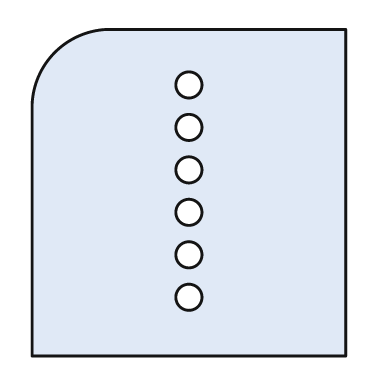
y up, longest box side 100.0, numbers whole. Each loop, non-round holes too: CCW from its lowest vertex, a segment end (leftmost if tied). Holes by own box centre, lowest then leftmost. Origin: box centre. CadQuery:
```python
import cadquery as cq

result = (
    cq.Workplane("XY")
    .moveTo(-48.0, -50.0)
    .lineTo(48.0, -50.0)
    .lineTo(48.0, 50.0)
    .lineTo(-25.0, 50.0)
    .threePointArc((-41.0, 43.0), (-48.0, 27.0))
    .close()
    .moveTo(0.0, -32.0)
    .circle(4.0)
    .moveTo(0.0, -19.0)
    .circle(4.0)
    .moveTo(0.0, -6.0)
    .circle(4.0)
    .moveTo(0.0, 7.0)
    .circle(4.0)
    .moveTo(0.0, 20.0)
    .circle(4.0)
    .moveTo(0.0, 33.0)
    .circle(4.0)
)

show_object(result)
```